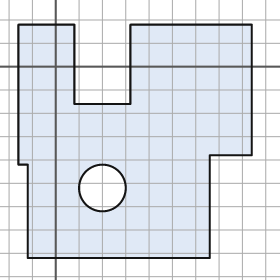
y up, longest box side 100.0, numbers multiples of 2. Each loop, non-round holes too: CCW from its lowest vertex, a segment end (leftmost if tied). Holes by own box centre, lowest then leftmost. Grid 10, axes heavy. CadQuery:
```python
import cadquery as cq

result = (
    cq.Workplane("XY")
    .moveTo(-12.0, -82.0)
    .lineTo(66.0, -82.0)
    .lineTo(66.0, -38.0)
    .lineTo(84.0, -38.0)
    .lineTo(84.0, 18.0)
    .lineTo(32.0, 18.0)
    .lineTo(32.0, -16.0)
    .lineTo(8.0, -16.0)
    .lineTo(8.0, 18.0)
    .lineTo(-16.0, 18.0)
    .lineTo(-16.0, -42.0)
    .lineTo(-12.0, -42.0)
    .close()
    .moveTo(20.0, -52.0)
    .circle(10.0)
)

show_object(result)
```